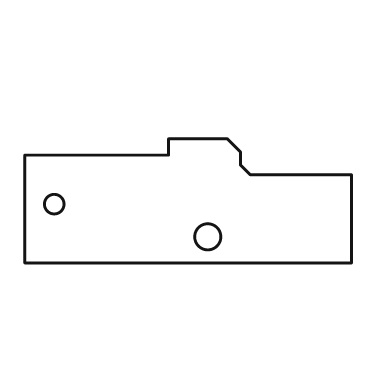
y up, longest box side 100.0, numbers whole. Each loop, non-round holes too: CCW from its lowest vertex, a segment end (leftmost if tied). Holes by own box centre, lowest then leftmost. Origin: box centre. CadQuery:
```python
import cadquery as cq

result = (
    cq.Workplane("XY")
    .moveTo(-50.0, -19.0)
    .lineTo(50.0, -19.0)
    .lineTo(50.0, 8.0)
    .lineTo(19.0, 8.0)
    .lineTo(16.0, 11.0)
    .lineTo(16.0, 15.0)
    .lineTo(12.0, 19.0)
    .lineTo(-6.0, 19.0)
    .lineTo(-6.0, 14.0)
    .lineTo(-50.0, 14.0)
    .close()
    .moveTo(6.0, -11.0)
    .circle(4.0)
    .moveTo(-41.0, -1.0)
    .circle(3.0)
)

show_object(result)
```